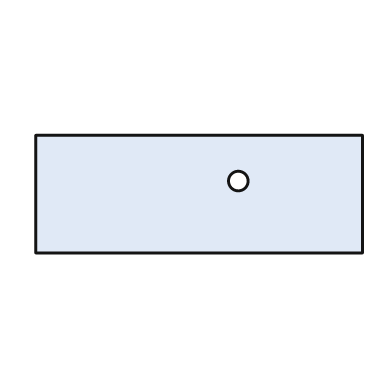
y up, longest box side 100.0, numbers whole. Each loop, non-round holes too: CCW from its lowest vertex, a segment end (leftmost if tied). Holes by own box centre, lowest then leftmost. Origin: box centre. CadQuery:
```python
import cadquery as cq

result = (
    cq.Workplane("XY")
    .moveTo(-50.0, -18.0)
    .lineTo(50.0, -18.0)
    .lineTo(50.0, 18.0)
    .lineTo(-50.0, 18.0)
    .close()
    .moveTo(12.0, 4.0)
    .circle(3.0)
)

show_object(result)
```